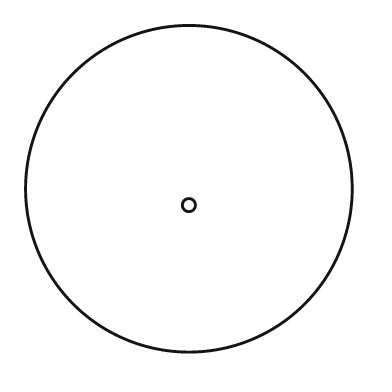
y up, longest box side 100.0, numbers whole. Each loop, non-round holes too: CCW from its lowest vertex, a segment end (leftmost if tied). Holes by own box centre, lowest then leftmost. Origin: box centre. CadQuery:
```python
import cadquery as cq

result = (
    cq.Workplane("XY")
    .moveTo(0.0, 0.0)
    .circle(50.0)
    .moveTo(0.0, -5.0)
    .circle(2.0)
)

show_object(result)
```